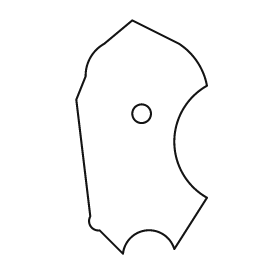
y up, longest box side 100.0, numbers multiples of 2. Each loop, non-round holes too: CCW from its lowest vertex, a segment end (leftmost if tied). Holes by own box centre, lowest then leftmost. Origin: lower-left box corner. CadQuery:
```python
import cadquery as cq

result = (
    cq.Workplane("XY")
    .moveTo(20.0, 0.0)
    .threePointArc((30.0, 10.0), (42.0, 2.0))
    .lineTo(56.0, 24.0)
    .threePointArc((42.0, 48.0), (56.0, 72.0))
    .threePointArc((52.0, 82.0), (44.0, 90.0))
    .lineTo(24.0, 100.0)
    .lineTo(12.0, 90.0)
    .threePointArc((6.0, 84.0), (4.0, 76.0))
    .lineTo(0.0, 66.0)
    .lineTo(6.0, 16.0)
    .threePointArc((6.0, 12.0), (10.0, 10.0))
    .close()
    .moveTo(28.0, 60.0)
    .circle(4.0)
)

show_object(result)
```